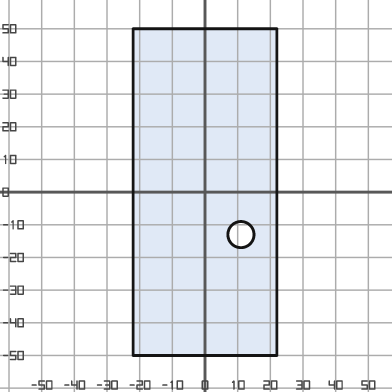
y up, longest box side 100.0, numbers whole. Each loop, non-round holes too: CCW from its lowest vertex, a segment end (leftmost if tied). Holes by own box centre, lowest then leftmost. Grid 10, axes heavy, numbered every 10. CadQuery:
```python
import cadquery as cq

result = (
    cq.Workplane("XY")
    .moveTo(-22.0, -50.0)
    .lineTo(22.0, -50.0)
    .lineTo(22.0, 50.0)
    .lineTo(-22.0, 50.0)
    .close()
    .moveTo(11.0, -13.0)
    .circle(4.0)
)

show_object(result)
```